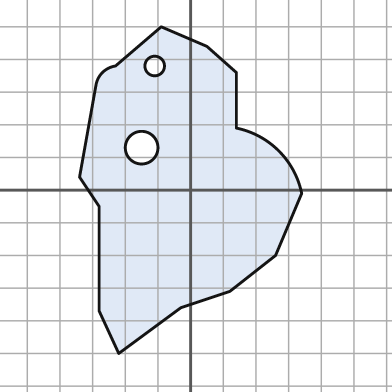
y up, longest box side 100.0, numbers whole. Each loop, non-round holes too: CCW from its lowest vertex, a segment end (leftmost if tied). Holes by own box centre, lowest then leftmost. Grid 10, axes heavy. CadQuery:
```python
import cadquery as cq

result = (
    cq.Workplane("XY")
    .moveTo(-22.0, -50.0)
    .lineTo(-3.0, -36.0)
    .lineTo(12.0, -31.0)
    .lineTo(26.0, -20.0)
    .lineTo(34.0, -1.0)
    .threePointArc((27.0, 12.0), (14.0, 19.0))
    .lineTo(14.0, 36.0)
    .lineTo(5.0, 44.0)
    .lineTo(-9.0, 50.0)
    .lineTo(-23.0, 38.0)
    .threePointArc((-27.0, 36.0), (-29.0, 32.0))
    .lineTo(-34.0, 4.0)
    .lineTo(-28.0, -5.0)
    .lineTo(-28.0, -37.0)
    .close()
    .moveTo(-15.0, 13.0)
    .circle(5.0)
    .moveTo(-11.0, 38.0)
    .circle(3.0)
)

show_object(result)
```